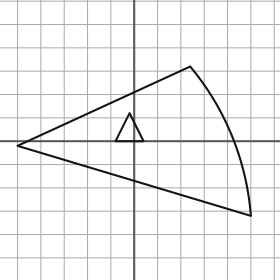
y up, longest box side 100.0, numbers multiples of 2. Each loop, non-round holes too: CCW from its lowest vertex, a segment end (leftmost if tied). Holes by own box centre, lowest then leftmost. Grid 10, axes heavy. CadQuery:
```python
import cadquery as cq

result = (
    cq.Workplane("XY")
    .moveTo(50.0, -32.0)
    .threePointArc((42.0, 2.0), (24.0, 32.0))
    .lineTo(-50.0, -2.0)
    .close()
    .moveTo(-8.0, 0.0)
    .lineTo(4.0, 0.0)
    .lineTo(-2.0, 12.0)
    .close()
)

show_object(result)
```